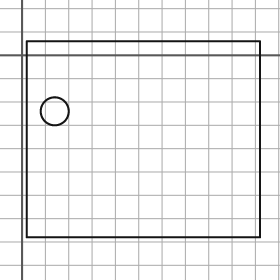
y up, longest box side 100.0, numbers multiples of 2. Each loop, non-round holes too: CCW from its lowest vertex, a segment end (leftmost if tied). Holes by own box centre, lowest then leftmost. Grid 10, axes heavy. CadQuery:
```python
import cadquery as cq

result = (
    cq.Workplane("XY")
    .moveTo(2.0, -78.0)
    .lineTo(102.0, -78.0)
    .lineTo(102.0, 6.0)
    .lineTo(2.0, 6.0)
    .close()
    .moveTo(14.0, -24.0)
    .circle(6.0)
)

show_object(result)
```